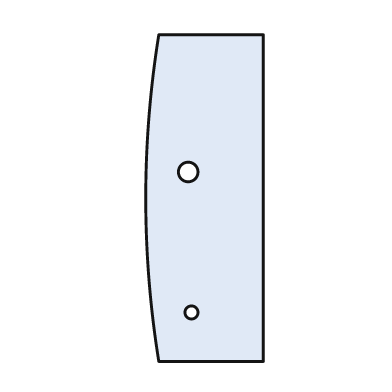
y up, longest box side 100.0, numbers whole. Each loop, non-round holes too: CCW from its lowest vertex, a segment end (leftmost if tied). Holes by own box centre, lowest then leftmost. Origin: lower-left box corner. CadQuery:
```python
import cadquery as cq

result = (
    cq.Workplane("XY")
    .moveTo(4.0, 0.0)
    .lineTo(36.0, 0.0)
    .lineTo(36.0, 100.0)
    .lineTo(4.0, 100.0)
    .threePointArc((0.0, 50.0), (4.0, 0.0))
    .close()
    .moveTo(14.0, 15.0)
    .circle(2.0)
    .moveTo(13.0, 58.0)
    .circle(3.0)
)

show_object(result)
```